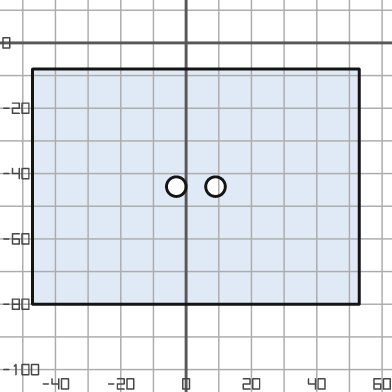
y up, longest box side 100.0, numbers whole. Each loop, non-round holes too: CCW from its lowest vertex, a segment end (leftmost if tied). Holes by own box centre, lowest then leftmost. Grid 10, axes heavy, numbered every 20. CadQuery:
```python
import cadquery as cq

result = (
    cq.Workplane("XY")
    .moveTo(-47.0, -80.0)
    .lineTo(53.0, -80.0)
    .lineTo(53.0, -8.0)
    .lineTo(-47.0, -8.0)
    .close()
    .moveTo(-3.0, -44.0)
    .circle(3.0)
    .moveTo(9.0, -44.0)
    .circle(3.0)
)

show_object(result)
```